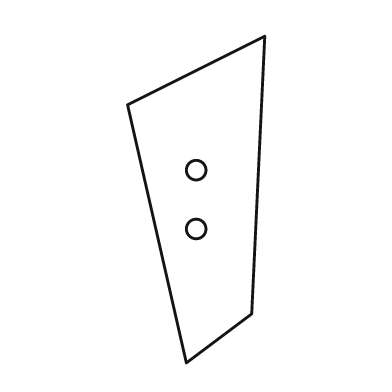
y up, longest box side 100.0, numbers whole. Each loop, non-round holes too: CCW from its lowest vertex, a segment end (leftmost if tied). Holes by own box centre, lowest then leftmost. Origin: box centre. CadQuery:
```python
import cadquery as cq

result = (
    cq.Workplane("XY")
    .moveTo(-3.0, -50.0)
    .lineTo(17.0, -35.0)
    .lineTo(21.0, 50.0)
    .lineTo(-21.0, 29.0)
    .close()
    .moveTo(0.0, -9.0)
    .circle(3.0)
    .moveTo(0.0, 9.0)
    .circle(3.0)
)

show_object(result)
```